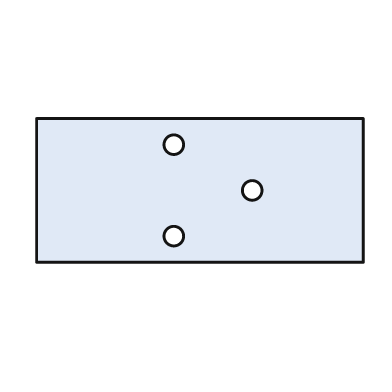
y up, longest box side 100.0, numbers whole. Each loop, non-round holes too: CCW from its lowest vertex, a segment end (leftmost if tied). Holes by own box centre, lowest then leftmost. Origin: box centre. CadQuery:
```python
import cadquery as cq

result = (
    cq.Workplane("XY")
    .moveTo(-50.0, -22.0)
    .lineTo(50.0, -22.0)
    .lineTo(50.0, 22.0)
    .lineTo(-50.0, 22.0)
    .close()
    .moveTo(-8.0, -14.0)
    .circle(3.0)
    .moveTo(16.0, 0.0)
    .circle(3.0)
    .moveTo(-8.0, 14.0)
    .circle(3.0)
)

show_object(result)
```